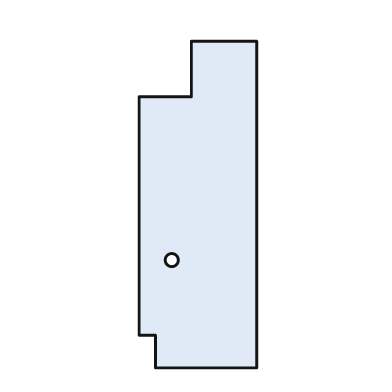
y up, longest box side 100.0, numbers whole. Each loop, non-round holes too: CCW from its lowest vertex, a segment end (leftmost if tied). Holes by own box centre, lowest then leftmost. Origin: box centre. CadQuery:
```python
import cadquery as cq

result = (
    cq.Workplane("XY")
    .moveTo(-13.0, -50.0)
    .lineTo(18.0, -50.0)
    .lineTo(18.0, 50.0)
    .lineTo(-2.0, 50.0)
    .lineTo(-2.0, 33.0)
    .lineTo(-18.0, 33.0)
    .lineTo(-18.0, -40.0)
    .lineTo(-13.0, -40.0)
    .close()
    .moveTo(-8.0, -17.0)
    .circle(2.0)
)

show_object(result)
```